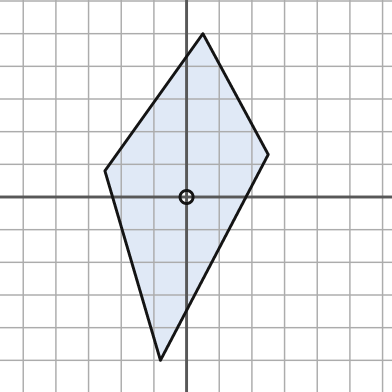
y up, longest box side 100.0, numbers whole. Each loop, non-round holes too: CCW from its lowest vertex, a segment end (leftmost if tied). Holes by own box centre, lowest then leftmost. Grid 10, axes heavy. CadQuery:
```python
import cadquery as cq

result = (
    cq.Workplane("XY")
    .moveTo(-8.0, -50.0)
    .lineTo(25.0, 13.0)
    .lineTo(5.0, 50.0)
    .lineTo(-25.0, 8.0)
    .close()
    .moveTo(0.0, 0.0)
    .circle(2.0)
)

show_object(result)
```